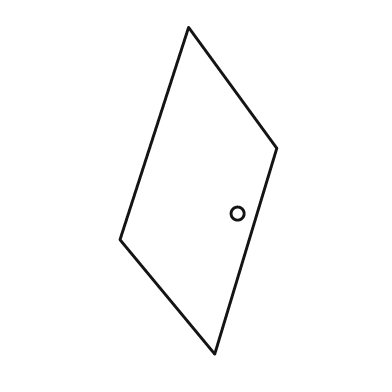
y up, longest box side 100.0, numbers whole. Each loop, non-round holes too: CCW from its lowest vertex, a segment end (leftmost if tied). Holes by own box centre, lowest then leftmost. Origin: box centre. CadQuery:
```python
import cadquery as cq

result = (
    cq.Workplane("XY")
    .moveTo(5.0, -50.0)
    .lineTo(24.0, 13.0)
    .lineTo(-3.0, 50.0)
    .lineTo(-24.0, -15.0)
    .close()
    .moveTo(12.0, -7.0)
    .circle(2.0)
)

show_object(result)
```